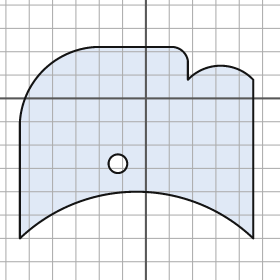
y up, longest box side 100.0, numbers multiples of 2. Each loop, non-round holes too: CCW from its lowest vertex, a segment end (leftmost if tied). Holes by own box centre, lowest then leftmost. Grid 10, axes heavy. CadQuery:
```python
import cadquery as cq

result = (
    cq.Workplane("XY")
    .moveTo(-54.0, -60.0)
    .threePointArc((-4.0, -40.0), (46.0, -60.0))
    .lineTo(46.0, 8.0)
    .threePointArc((32.0, 14.0), (18.0, 8.0))
    .lineTo(18.0, 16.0)
    .threePointArc((16.0, 20.0), (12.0, 22.0))
    .lineTo(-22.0, 22.0)
    .threePointArc((-44.0, 12.0), (-54.0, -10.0))
    .close()
    .moveTo(-12.0, -28.0)
    .circle(4.0)
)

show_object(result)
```